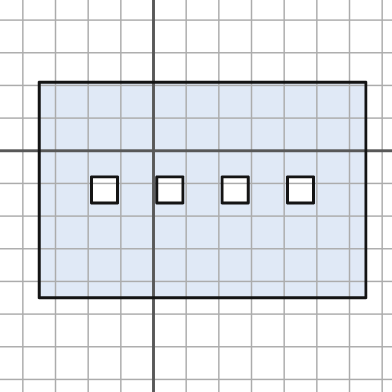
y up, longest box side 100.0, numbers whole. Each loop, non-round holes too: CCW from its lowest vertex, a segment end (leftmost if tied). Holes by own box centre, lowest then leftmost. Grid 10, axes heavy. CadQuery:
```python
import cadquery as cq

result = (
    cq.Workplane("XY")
    .moveTo(-35.0, -45.0)
    .lineTo(65.0, -45.0)
    .lineTo(65.0, 21.0)
    .lineTo(-35.0, 21.0)
    .close()
    .moveTo(-19.0, -16.0)
    .lineTo(-11.0, -16.0)
    .lineTo(-11.0, -8.0)
    .lineTo(-19.0, -8.0)
    .close()
    .moveTo(1.0, -16.0)
    .lineTo(9.0, -16.0)
    .lineTo(9.0, -8.0)
    .lineTo(1.0, -8.0)
    .close()
    .moveTo(21.0, -16.0)
    .lineTo(29.0, -16.0)
    .lineTo(29.0, -8.0)
    .lineTo(21.0, -8.0)
    .close()
    .moveTo(41.0, -16.0)
    .lineTo(49.0, -16.0)
    .lineTo(49.0, -8.0)
    .lineTo(41.0, -8.0)
    .close()
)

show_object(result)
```